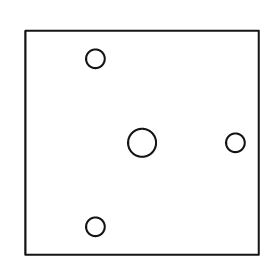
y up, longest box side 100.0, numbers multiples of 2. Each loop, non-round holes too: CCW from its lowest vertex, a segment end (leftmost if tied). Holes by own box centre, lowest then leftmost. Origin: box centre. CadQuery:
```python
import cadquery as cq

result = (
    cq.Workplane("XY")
    .moveTo(-50.0, -48.0)
    .lineTo(50.0, -48.0)
    .lineTo(50.0, 48.0)
    .lineTo(-50.0, 48.0)
    .close()
    .moveTo(-20.0, -36.0)
    .circle(4.0)
    .moveTo(0.0, 0.0)
    .circle(6.0)
    .moveTo(40.0, 0.0)
    .circle(4.0)
    .moveTo(-20.0, 36.0)
    .circle(4.0)
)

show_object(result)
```